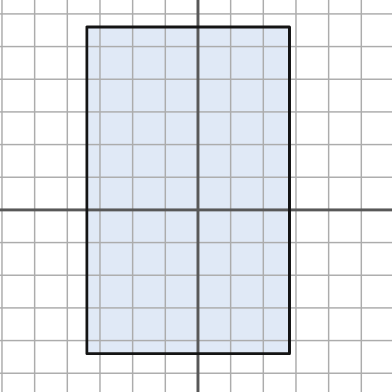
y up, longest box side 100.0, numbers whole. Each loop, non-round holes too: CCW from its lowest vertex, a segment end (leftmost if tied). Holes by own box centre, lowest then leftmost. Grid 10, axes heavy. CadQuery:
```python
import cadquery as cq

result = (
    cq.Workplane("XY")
    .moveTo(-34.0, -44.0)
    .lineTo(28.0, -44.0)
    .lineTo(28.0, 56.0)
    .lineTo(-34.0, 56.0)
    .close()
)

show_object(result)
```